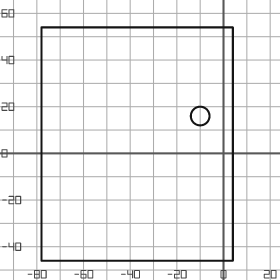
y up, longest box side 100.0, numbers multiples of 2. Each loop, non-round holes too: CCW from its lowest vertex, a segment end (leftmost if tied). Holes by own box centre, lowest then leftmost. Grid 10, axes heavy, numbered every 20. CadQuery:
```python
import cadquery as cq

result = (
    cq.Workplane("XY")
    .moveTo(-78.0, -46.0)
    .lineTo(4.0, -46.0)
    .lineTo(4.0, 54.0)
    .lineTo(-78.0, 54.0)
    .close()
    .moveTo(-10.0, 16.0)
    .circle(4.0)
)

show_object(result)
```